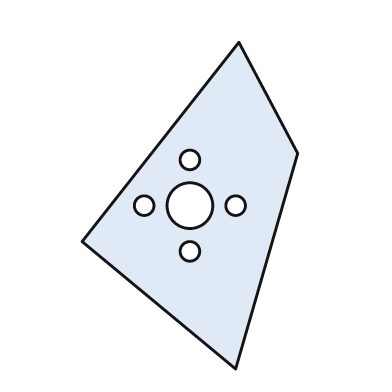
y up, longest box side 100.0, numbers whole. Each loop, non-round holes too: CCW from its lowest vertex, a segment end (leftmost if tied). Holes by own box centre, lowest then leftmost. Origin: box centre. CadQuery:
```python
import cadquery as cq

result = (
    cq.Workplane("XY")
    .moveTo(14.0, -50.0)
    .lineTo(33.0, 16.0)
    .lineTo(15.0, 50.0)
    .lineTo(-33.0, -11.0)
    .close()
    .moveTo(0.0, -14.0)
    .circle(3.0)
    .moveTo(-14.0, 0.0)
    .circle(3.0)
    .moveTo(0.0, 0.0)
    .circle(7.0)
    .moveTo(14.0, 0.0)
    .circle(3.0)
    .moveTo(0.0, 14.0)
    .circle(3.0)
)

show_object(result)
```